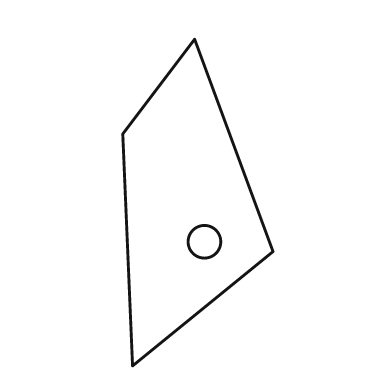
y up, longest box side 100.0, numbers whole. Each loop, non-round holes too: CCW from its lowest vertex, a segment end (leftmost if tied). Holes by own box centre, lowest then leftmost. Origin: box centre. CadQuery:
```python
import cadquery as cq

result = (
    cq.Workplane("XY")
    .moveTo(-20.0, -50.0)
    .lineTo(23.0, -15.0)
    .lineTo(-1.0, 50.0)
    .lineTo(-23.0, 21.0)
    .close()
    .moveTo(2.0, -12.0)
    .circle(5.0)
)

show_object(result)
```